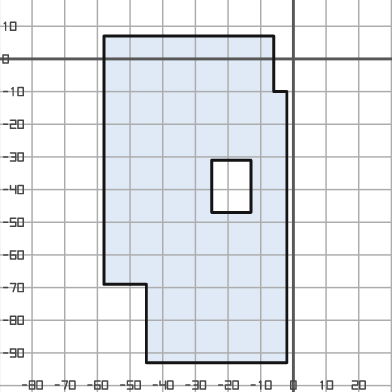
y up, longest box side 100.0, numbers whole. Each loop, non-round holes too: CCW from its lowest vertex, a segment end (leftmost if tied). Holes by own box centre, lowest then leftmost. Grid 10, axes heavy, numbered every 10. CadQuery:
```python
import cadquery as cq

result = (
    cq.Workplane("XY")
    .moveTo(-45.0, -93.0)
    .lineTo(-2.0, -93.0)
    .lineTo(-2.0, -10.0)
    .lineTo(-6.0, -10.0)
    .lineTo(-6.0, 7.0)
    .lineTo(-58.0, 7.0)
    .lineTo(-58.0, -69.0)
    .lineTo(-45.0, -69.0)
    .close()
    .moveTo(-25.0, -47.0)
    .lineTo(-13.0, -47.0)
    .lineTo(-13.0, -31.0)
    .lineTo(-25.0, -31.0)
    .close()
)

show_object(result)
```